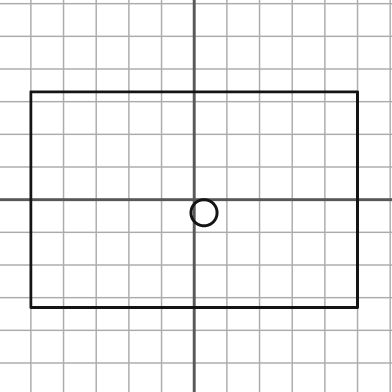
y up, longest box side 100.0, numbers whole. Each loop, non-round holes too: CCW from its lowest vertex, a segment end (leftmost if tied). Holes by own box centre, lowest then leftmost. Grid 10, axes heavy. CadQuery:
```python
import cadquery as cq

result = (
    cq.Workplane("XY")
    .moveTo(-50.0, -33.0)
    .lineTo(50.0, -33.0)
    .lineTo(50.0, 33.0)
    .lineTo(-50.0, 33.0)
    .close()
    .moveTo(3.0, -4.0)
    .circle(4.0)
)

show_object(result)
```